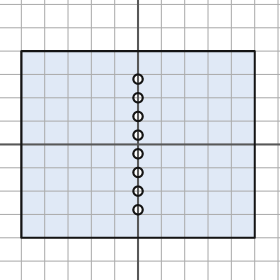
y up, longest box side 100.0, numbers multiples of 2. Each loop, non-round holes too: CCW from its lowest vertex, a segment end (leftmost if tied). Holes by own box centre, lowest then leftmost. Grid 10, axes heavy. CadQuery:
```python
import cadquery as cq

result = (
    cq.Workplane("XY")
    .moveTo(-50.0, -40.0)
    .lineTo(50.0, -40.0)
    .lineTo(50.0, 40.0)
    .lineTo(-50.0, 40.0)
    .close()
    .moveTo(0.0, -28.0)
    .circle(2.0)
    .moveTo(0.0, -20.0)
    .circle(2.0)
    .moveTo(0.0, -12.0)
    .circle(2.0)
    .moveTo(0.0, -4.0)
    .circle(2.0)
    .moveTo(0.0, 4.0)
    .circle(2.0)
    .moveTo(0.0, 12.0)
    .circle(2.0)
    .moveTo(0.0, 20.0)
    .circle(2.0)
    .moveTo(0.0, 28.0)
    .circle(2.0)
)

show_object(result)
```